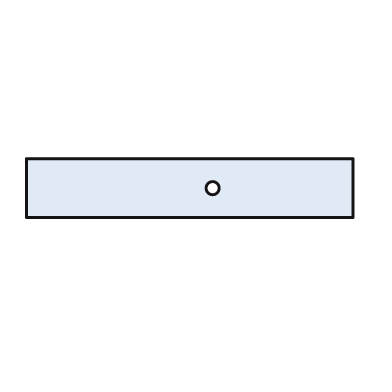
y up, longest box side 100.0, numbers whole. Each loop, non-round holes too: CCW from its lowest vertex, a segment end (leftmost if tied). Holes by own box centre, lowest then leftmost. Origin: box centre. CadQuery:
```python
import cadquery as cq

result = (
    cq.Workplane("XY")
    .moveTo(-50.0, -9.0)
    .lineTo(50.0, -9.0)
    .lineTo(50.0, 9.0)
    .lineTo(-50.0, 9.0)
    .close()
    .moveTo(7.0, 0.0)
    .circle(2.0)
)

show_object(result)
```